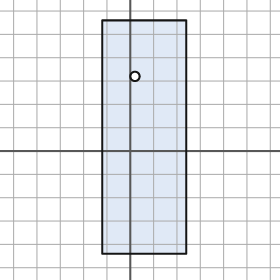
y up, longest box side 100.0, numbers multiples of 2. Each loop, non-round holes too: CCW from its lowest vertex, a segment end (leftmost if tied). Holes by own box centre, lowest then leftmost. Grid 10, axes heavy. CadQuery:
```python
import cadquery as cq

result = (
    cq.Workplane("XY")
    .moveTo(-12.0, -44.0)
    .lineTo(24.0, -44.0)
    .lineTo(24.0, 56.0)
    .lineTo(-12.0, 56.0)
    .close()
    .moveTo(2.0, 32.0)
    .circle(2.0)
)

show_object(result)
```